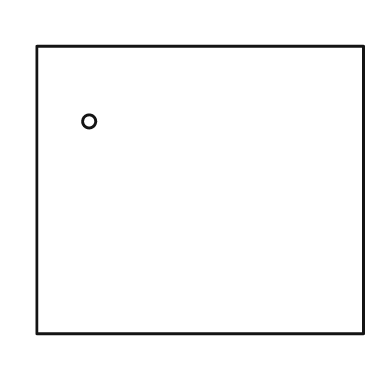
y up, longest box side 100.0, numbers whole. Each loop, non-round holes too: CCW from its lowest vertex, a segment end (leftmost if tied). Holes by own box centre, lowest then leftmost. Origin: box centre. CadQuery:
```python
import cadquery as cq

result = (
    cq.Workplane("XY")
    .moveTo(-50.0, -44.0)
    .lineTo(50.0, -44.0)
    .lineTo(50.0, 44.0)
    .lineTo(-50.0, 44.0)
    .close()
    .moveTo(-34.0, 21.0)
    .circle(2.0)
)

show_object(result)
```